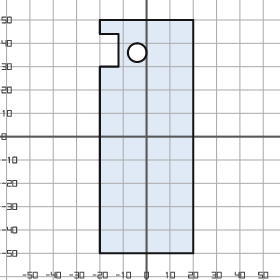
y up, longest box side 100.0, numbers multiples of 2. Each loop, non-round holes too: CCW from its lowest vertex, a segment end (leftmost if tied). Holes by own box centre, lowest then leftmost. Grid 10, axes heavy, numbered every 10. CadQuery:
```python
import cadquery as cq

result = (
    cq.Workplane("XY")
    .moveTo(-20.0, -50.0)
    .lineTo(20.0, -50.0)
    .lineTo(20.0, 50.0)
    .lineTo(-20.0, 50.0)
    .lineTo(-20.0, 44.0)
    .lineTo(-12.0, 44.0)
    .lineTo(-12.0, 30.0)
    .lineTo(-20.0, 30.0)
    .close()
    .moveTo(-4.0, 36.0)
    .circle(4.0)
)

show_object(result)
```